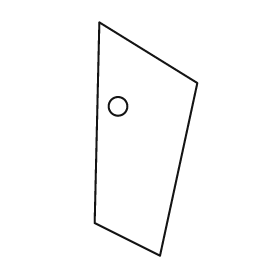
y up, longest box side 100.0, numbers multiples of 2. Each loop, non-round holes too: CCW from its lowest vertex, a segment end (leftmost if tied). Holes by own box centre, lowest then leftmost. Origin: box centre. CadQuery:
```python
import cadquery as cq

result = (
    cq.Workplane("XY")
    .moveTo(6.0, -50.0)
    .lineTo(22.0, 24.0)
    .lineTo(-20.0, 50.0)
    .lineTo(-22.0, -36.0)
    .close()
    .moveTo(-12.0, 14.0)
    .circle(4.0)
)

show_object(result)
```